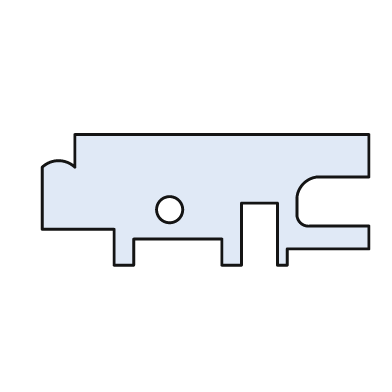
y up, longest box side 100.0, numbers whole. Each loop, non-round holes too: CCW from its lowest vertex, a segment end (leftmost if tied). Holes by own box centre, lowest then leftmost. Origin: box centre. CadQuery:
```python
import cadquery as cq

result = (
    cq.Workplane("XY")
    .moveTo(-28.0, -20.0)
    .lineTo(-22.0, -20.0)
    .lineTo(-22.0, -12.0)
    .lineTo(5.0, -12.0)
    .lineTo(5.0, -20.0)
    .lineTo(11.0, -20.0)
    .lineTo(11.0, -1.0)
    .lineTo(22.0, -1.0)
    .lineTo(22.0, -20.0)
    .lineTo(25.0, -20.0)
    .lineTo(25.0, -15.0)
    .lineTo(50.0, -15.0)
    .lineTo(50.0, -8.0)
    .lineTo(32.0, -8.0)
    .threePointArc((29.0, -7.0), (28.0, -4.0))
    .lineTo(28.0, 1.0)
    .threePointArc((30.0, 5.0), (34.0, 7.0))
    .lineTo(50.0, 7.0)
    .lineTo(50.0, 20.0)
    .lineTo(-40.0, 20.0)
    .lineTo(-40.0, 10.0)
    .threePointArc((-45.0, 12.0), (-50.0, 10.0))
    .lineTo(-50.0, -9.0)
    .lineTo(-28.0, -9.0)
    .close()
    .moveTo(-11.0, -3.0)
    .circle(4.0)
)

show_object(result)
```